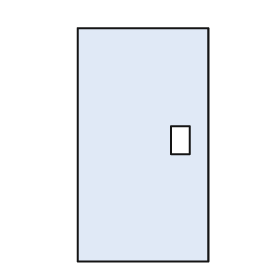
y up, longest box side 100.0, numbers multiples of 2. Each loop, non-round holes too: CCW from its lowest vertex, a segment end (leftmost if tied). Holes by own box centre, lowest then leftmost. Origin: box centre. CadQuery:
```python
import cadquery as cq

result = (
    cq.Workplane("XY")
    .moveTo(-28.0, -50.0)
    .lineTo(28.0, -50.0)
    .lineTo(28.0, 50.0)
    .lineTo(-28.0, 50.0)
    .close()
    .moveTo(12.0, -4.0)
    .lineTo(20.0, -4.0)
    .lineTo(20.0, 8.0)
    .lineTo(12.0, 8.0)
    .close()
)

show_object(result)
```